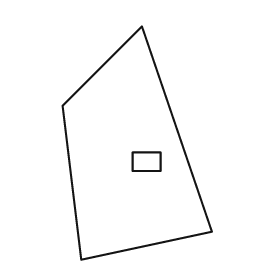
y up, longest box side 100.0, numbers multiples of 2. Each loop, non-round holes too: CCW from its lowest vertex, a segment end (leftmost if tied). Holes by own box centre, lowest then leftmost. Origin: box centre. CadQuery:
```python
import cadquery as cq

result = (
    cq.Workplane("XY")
    .moveTo(-24.0, -50.0)
    .lineTo(32.0, -38.0)
    .lineTo(2.0, 50.0)
    .lineTo(-32.0, 16.0)
    .close()
    .moveTo(-2.0, -12.0)
    .lineTo(10.0, -12.0)
    .lineTo(10.0, -4.0)
    .lineTo(-2.0, -4.0)
    .close()
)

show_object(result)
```